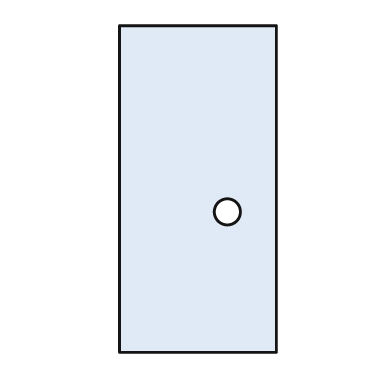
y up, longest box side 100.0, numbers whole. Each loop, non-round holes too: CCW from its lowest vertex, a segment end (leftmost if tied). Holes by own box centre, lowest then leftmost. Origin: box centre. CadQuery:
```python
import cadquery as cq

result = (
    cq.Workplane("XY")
    .moveTo(-24.0, -50.0)
    .lineTo(24.0, -50.0)
    .lineTo(24.0, 50.0)
    .lineTo(-24.0, 50.0)
    .close()
    .moveTo(9.0, -7.0)
    .circle(4.0)
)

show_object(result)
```